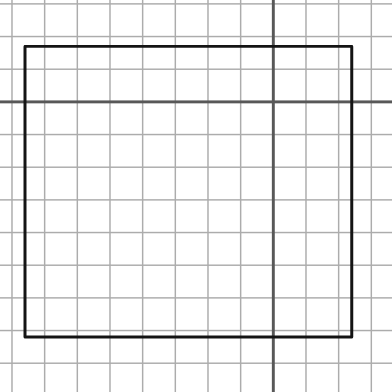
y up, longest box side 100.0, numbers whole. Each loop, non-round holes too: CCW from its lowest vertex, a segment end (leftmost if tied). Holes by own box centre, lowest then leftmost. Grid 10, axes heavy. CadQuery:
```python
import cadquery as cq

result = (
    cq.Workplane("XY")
    .moveTo(-76.0, -72.0)
    .lineTo(24.0, -72.0)
    .lineTo(24.0, 17.0)
    .lineTo(-76.0, 17.0)
    .close()
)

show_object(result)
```